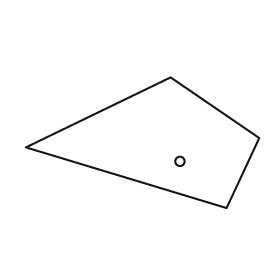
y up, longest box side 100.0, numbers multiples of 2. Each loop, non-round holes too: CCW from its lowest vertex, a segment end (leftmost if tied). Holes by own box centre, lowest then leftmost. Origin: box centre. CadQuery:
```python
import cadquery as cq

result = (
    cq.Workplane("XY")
    .moveTo(36.0, -28.0)
    .lineTo(50.0, 2.0)
    .lineTo(12.0, 28.0)
    .lineTo(-50.0, -2.0)
    .close()
    .moveTo(16.0, -8.0)
    .circle(2.0)
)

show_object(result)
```